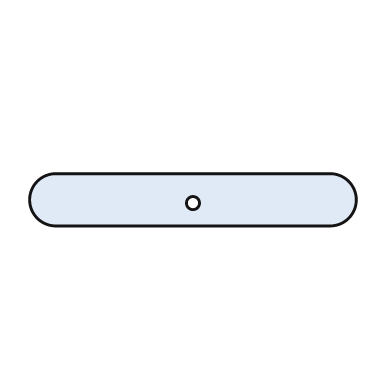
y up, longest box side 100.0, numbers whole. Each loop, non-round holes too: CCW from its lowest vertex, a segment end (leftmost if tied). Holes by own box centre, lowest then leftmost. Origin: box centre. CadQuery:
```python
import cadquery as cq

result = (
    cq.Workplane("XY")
    .moveTo(-42.0, -8.0)
    .lineTo(42.0, -8.0)
    .threePointArc((50.0, 0.0), (42.0, 8.0))
    .lineTo(-42.0, 8.0)
    .threePointArc((-50.0, 0.0), (-42.0, -8.0))
    .close()
    .moveTo(0.0, -1.0)
    .circle(2.0)
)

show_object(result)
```